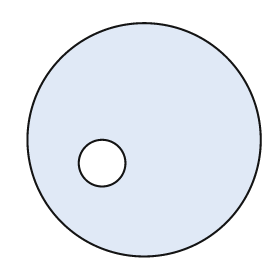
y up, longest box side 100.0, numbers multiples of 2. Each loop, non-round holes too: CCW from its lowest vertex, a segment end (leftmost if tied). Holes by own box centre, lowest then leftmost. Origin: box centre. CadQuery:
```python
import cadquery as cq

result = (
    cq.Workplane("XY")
    .moveTo(0.0, 0.0)
    .circle(50.0)
    .moveTo(-18.0, -10.0)
    .circle(10.0)
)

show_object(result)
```